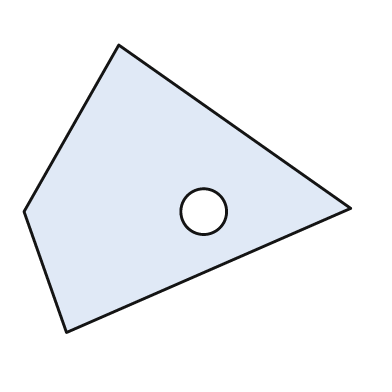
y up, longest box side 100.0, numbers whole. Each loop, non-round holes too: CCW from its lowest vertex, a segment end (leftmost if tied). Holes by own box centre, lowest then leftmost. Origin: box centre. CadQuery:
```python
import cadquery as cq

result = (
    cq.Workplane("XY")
    .moveTo(-37.0, -44.0)
    .lineTo(50.0, -6.0)
    .lineTo(-21.0, 44.0)
    .lineTo(-50.0, -7.0)
    .close()
    .moveTo(5.0, -7.0)
    .circle(7.0)
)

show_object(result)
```